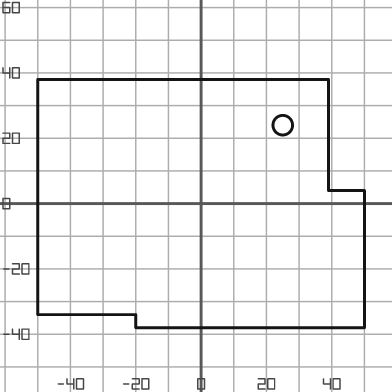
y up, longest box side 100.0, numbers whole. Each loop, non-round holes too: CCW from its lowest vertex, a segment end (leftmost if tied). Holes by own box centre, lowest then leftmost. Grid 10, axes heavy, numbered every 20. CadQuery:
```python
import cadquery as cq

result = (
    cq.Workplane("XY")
    .moveTo(-20.0, -38.0)
    .lineTo(50.0, -38.0)
    .lineTo(50.0, 4.0)
    .lineTo(39.0, 4.0)
    .lineTo(39.0, 38.0)
    .lineTo(-50.0, 38.0)
    .lineTo(-50.0, -34.0)
    .lineTo(-20.0, -34.0)
    .close()
    .moveTo(25.0, 24.0)
    .circle(3.0)
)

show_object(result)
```